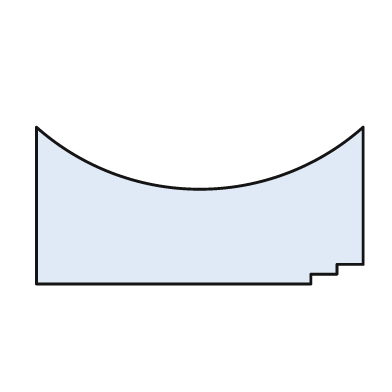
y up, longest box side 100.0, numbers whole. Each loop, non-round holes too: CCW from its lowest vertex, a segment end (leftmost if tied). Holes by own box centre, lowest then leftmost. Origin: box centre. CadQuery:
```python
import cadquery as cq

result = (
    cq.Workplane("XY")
    .moveTo(-50.0, -24.0)
    .lineTo(34.0, -24.0)
    .lineTo(34.0, -21.0)
    .lineTo(42.0, -21.0)
    .lineTo(42.0, -18.0)
    .lineTo(50.0, -18.0)
    .lineTo(50.0, 24.0)
    .threePointArc((0.0, 5.0), (-50.0, 24.0))
    .close()
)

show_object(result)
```